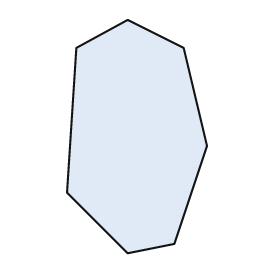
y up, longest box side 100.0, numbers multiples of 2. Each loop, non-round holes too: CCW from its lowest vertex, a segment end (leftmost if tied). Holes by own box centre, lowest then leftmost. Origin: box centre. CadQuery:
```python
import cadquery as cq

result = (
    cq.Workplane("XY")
    .moveTo(-4.0, -50.0)
    .lineTo(16.0, -46.0)
    .lineTo(30.0, -4.0)
    .lineTo(20.0, 38.0)
    .lineTo(-4.0, 50.0)
    .lineTo(-26.0, 38.0)
    .lineTo(-30.0, -24.0)
    .close()
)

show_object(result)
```